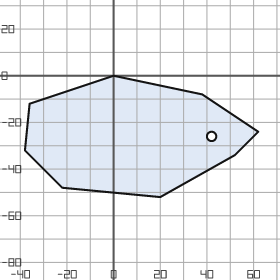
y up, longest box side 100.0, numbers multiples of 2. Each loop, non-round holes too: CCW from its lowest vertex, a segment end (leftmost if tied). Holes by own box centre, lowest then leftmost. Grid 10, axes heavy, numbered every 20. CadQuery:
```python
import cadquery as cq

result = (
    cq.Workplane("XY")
    .moveTo(20.0, -52.0)
    .lineTo(52.0, -34.0)
    .lineTo(62.0, -24.0)
    .lineTo(38.0, -8.0)
    .lineTo(0.0, 0.0)
    .lineTo(-36.0, -12.0)
    .lineTo(-38.0, -32.0)
    .lineTo(-22.0, -48.0)
    .close()
    .moveTo(42.0, -26.0)
    .circle(2.0)
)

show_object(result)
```